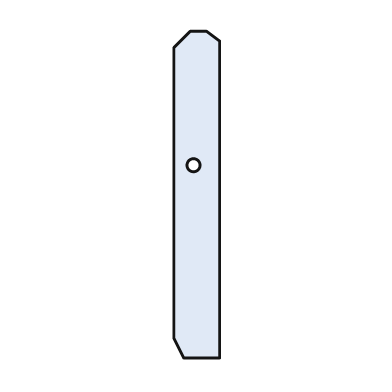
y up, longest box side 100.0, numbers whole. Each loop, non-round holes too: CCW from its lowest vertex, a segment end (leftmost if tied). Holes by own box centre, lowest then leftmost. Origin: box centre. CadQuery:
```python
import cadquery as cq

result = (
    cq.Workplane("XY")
    .moveTo(-4.0, -50.0)
    .lineTo(7.0, -50.0)
    .lineTo(7.0, 47.0)
    .lineTo(3.0, 50.0)
    .lineTo(-2.0, 50.0)
    .lineTo(-7.0, 45.0)
    .lineTo(-7.0, -44.0)
    .close()
    .moveTo(-1.0, 9.0)
    .circle(2.0)
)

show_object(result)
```